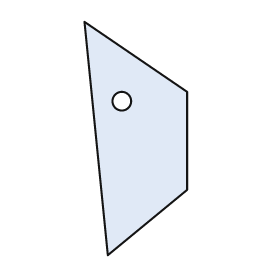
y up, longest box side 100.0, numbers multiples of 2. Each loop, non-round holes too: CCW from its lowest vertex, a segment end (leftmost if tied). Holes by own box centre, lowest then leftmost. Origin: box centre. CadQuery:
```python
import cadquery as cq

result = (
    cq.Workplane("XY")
    .moveTo(-12.0, -50.0)
    .lineTo(22.0, -22.0)
    .lineTo(22.0, 20.0)
    .lineTo(-22.0, 50.0)
    .close()
    .moveTo(-6.0, 16.0)
    .circle(4.0)
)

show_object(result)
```